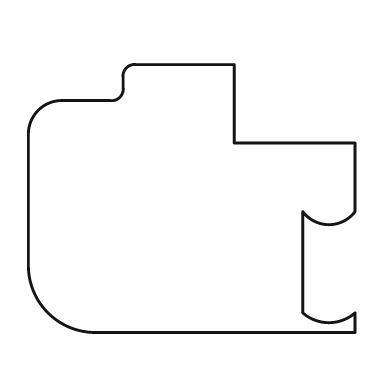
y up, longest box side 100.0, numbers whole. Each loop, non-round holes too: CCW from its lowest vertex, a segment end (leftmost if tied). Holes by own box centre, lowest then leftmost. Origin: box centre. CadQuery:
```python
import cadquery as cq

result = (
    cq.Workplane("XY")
    .moveTo(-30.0, -41.0)
    .lineTo(50.0, -41.0)
    .lineTo(50.0, -35.0)
    .threePointArc((42.0, -38.0), (34.0, -35.0))
    .lineTo(34.0, -4.0)
    .threePointArc((42.0, -8.0), (50.0, -4.0))
    .lineTo(50.0, 17.0)
    .lineTo(13.0, 17.0)
    .lineTo(13.0, 41.0)
    .lineTo(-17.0, 41.0)
    .threePointArc((-20.0, 40.0), (-21.0, 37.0))
    .lineTo(-21.0, 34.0)
    .threePointArc((-22.0, 31.0), (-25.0, 30.0))
    .lineTo(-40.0, 30.0)
    .threePointArc((-47.0, 27.0), (-50.0, 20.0))
    .lineTo(-50.0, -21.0)
    .threePointArc((-44.0, -35.0), (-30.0, -41.0))
    .close()
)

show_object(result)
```